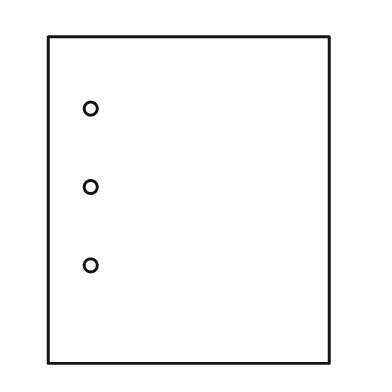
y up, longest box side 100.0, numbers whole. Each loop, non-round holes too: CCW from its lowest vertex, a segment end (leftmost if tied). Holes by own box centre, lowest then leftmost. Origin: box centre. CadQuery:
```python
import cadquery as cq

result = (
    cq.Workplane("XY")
    .moveTo(-43.0, -50.0)
    .lineTo(43.0, -50.0)
    .lineTo(43.0, 50.0)
    .lineTo(-43.0, 50.0)
    .close()
    .moveTo(-30.0, -20.0)
    .circle(2.0)
    .moveTo(-30.0, 4.0)
    .circle(2.0)
    .moveTo(-30.0, 28.0)
    .circle(2.0)
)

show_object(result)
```